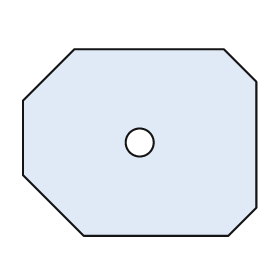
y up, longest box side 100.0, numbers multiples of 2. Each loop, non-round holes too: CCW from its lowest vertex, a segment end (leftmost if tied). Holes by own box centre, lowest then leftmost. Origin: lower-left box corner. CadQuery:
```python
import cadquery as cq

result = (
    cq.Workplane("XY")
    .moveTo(26.0, 0.0)
    .lineTo(88.0, 0.0)
    .lineTo(100.0, 12.0)
    .lineTo(100.0, 66.0)
    .lineTo(86.0, 80.0)
    .lineTo(22.0, 80.0)
    .lineTo(0.0, 58.0)
    .lineTo(0.0, 26.0)
    .close()
    .moveTo(50.0, 40.0)
    .circle(6.0)
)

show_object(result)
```